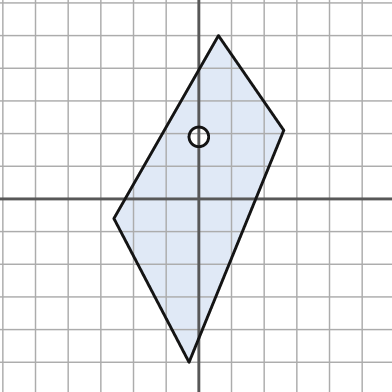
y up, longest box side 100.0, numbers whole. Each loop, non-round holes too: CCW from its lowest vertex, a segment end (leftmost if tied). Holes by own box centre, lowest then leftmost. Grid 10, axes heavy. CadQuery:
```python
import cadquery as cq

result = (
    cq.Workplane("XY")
    .moveTo(-3.0, -50.0)
    .lineTo(26.0, 21.0)
    .lineTo(6.0, 50.0)
    .lineTo(-26.0, -6.0)
    .close()
    .moveTo(0.0, 19.0)
    .circle(3.0)
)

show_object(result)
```